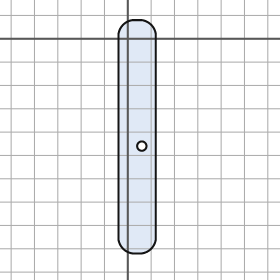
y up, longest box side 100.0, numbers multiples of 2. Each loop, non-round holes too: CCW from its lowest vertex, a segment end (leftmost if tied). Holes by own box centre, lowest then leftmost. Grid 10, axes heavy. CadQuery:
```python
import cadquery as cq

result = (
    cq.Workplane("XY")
    .moveTo(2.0, -92.0)
    .lineTo(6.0, -92.0)
    .threePointArc((10.0, -90.0), (12.0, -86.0))
    .lineTo(12.0, 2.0)
    .threePointArc((10.0, 6.0), (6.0, 8.0))
    .lineTo(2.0, 8.0)
    .threePointArc((-2.0, 6.0), (-4.0, 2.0))
    .lineTo(-4.0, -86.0)
    .threePointArc((-2.0, -90.0), (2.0, -92.0))
    .close()
    .moveTo(6.0, -46.0)
    .circle(2.0)
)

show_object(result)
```